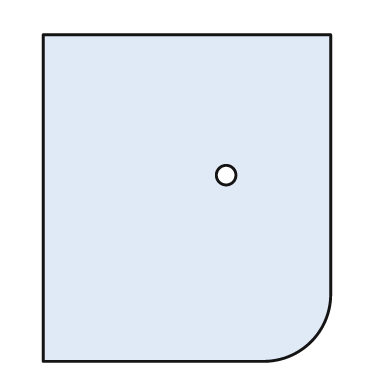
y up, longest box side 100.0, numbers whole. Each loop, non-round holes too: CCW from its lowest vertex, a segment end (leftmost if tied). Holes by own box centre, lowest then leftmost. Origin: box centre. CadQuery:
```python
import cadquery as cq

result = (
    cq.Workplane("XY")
    .moveTo(-44.0, -50.0)
    .lineTo(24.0, -50.0)
    .threePointArc((38.0, -44.0), (44.0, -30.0))
    .lineTo(44.0, 50.0)
    .lineTo(-44.0, 50.0)
    .close()
    .moveTo(12.0, 7.0)
    .circle(3.0)
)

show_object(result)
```